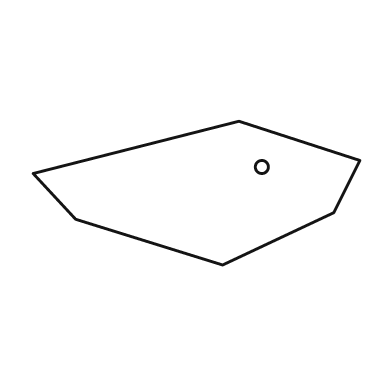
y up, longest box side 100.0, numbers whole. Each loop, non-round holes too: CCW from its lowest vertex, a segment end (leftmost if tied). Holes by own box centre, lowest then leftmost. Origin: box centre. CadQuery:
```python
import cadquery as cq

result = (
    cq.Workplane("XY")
    .moveTo(8.0, -22.0)
    .lineTo(42.0, -6.0)
    .lineTo(50.0, 10.0)
    .lineTo(13.0, 22.0)
    .lineTo(-50.0, 6.0)
    .lineTo(-37.0, -8.0)
    .close()
    .moveTo(20.0, 8.0)
    .circle(2.0)
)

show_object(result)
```